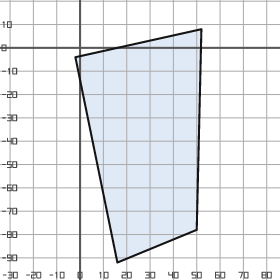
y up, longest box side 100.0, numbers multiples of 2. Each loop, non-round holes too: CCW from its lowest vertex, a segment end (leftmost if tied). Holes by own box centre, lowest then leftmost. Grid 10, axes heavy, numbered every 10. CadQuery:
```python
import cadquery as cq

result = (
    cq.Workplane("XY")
    .moveTo(16.0, -92.0)
    .lineTo(50.0, -78.0)
    .lineTo(52.0, 8.0)
    .lineTo(-2.0, -4.0)
    .close()
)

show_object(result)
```